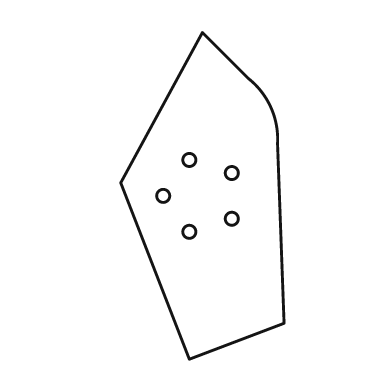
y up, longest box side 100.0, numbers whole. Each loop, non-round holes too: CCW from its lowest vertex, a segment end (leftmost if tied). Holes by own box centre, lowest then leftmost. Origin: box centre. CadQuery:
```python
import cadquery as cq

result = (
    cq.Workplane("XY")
    .moveTo(-4.0, -50.0)
    .lineTo(25.0, -39.0)
    .lineTo(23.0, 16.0)
    .threePointArc((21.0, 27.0), (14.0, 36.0))
    .lineTo(0.0, 50.0)
    .lineTo(-25.0, 4.0)
    .close()
    .moveTo(-4.0, -11.0)
    .circle(2.0)
    .moveTo(9.0, -7.0)
    .circle(2.0)
    .moveTo(-12.0, 0.0)
    .circle(2.0)
    .moveTo(9.0, 7.0)
    .circle(2.0)
    .moveTo(-4.0, 11.0)
    .circle(2.0)
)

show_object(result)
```